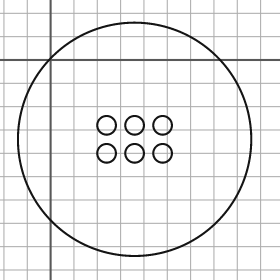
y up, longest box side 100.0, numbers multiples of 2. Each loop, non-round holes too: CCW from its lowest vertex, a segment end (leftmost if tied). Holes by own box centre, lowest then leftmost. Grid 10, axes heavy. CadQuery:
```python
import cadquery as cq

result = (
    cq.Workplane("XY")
    .moveTo(36.0, -34.0)
    .circle(50.0)
    .moveTo(24.0, -40.0)
    .circle(4.0)
    .moveTo(36.0, -40.0)
    .circle(4.0)
    .moveTo(48.0, -40.0)
    .circle(4.0)
    .moveTo(24.0, -28.0)
    .circle(4.0)
    .moveTo(36.0, -28.0)
    .circle(4.0)
    .moveTo(48.0, -28.0)
    .circle(4.0)
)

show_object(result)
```